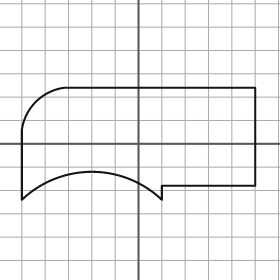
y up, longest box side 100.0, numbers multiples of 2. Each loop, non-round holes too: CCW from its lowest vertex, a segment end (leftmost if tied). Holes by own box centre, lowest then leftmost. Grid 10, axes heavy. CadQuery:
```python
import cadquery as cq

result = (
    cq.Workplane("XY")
    .moveTo(-50.0, -24.0)
    .threePointArc((-20.0, -12.0), (10.0, -24.0))
    .lineTo(10.0, -18.0)
    .lineTo(50.0, -18.0)
    .lineTo(50.0, 24.0)
    .lineTo(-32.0, 24.0)
    .threePointArc((-44.0, 18.0), (-50.0, 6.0))
    .close()
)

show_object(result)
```